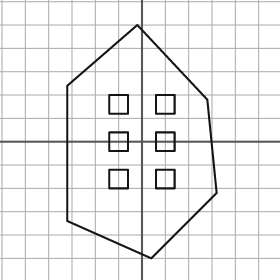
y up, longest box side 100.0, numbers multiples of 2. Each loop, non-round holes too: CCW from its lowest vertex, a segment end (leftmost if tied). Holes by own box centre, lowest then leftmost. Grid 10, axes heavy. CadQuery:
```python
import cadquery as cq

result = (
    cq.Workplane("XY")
    .moveTo(4.0, -50.0)
    .lineTo(32.0, -22.0)
    .lineTo(28.0, 18.0)
    .lineTo(-2.0, 50.0)
    .lineTo(-32.0, 24.0)
    .lineTo(-32.0, -34.0)
    .close()
    .moveTo(-14.0, -20.0)
    .lineTo(-6.0, -20.0)
    .lineTo(-6.0, -12.0)
    .lineTo(-14.0, -12.0)
    .close()
    .moveTo(6.0, -20.0)
    .lineTo(14.0, -20.0)
    .lineTo(14.0, -12.0)
    .lineTo(6.0, -12.0)
    .close()
    .moveTo(-14.0, -4.0)
    .lineTo(-6.0, -4.0)
    .lineTo(-6.0, 4.0)
    .lineTo(-14.0, 4.0)
    .close()
    .moveTo(6.0, -4.0)
    .lineTo(14.0, -4.0)
    .lineTo(14.0, 4.0)
    .lineTo(6.0, 4.0)
    .close()
    .moveTo(-14.0, 12.0)
    .lineTo(-6.0, 12.0)
    .lineTo(-6.0, 20.0)
    .lineTo(-14.0, 20.0)
    .close()
    .moveTo(6.0, 12.0)
    .lineTo(14.0, 12.0)
    .lineTo(14.0, 20.0)
    .lineTo(6.0, 20.0)
    .close()
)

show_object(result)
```